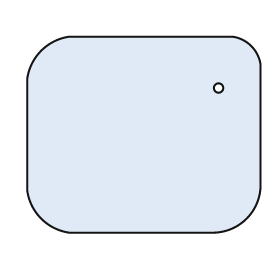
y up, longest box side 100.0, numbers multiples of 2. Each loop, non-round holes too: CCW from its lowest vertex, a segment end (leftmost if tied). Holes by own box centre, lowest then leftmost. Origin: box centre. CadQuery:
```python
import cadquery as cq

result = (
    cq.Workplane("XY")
    .moveTo(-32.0, -42.0)
    .lineTo(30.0, -42.0)
    .threePointArc((44.0, -36.0), (50.0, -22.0))
    .lineTo(50.0, 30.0)
    .threePointArc((46.0, 38.0), (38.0, 42.0))
    .lineTo(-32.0, 42.0)
    .threePointArc((-44.0, 36.0), (-50.0, 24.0))
    .lineTo(-50.0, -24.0)
    .threePointArc((-44.0, -36.0), (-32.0, -42.0))
    .close()
    .moveTo(32.0, 20.0)
    .circle(2.0)
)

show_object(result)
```